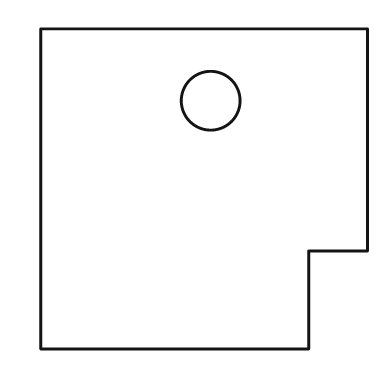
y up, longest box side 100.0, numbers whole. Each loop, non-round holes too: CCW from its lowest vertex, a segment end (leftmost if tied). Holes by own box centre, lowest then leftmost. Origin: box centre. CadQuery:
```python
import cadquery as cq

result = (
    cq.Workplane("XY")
    .moveTo(-50.0, -49.0)
    .lineTo(32.0, -49.0)
    .lineTo(32.0, -19.0)
    .lineTo(50.0, -19.0)
    .lineTo(50.0, 49.0)
    .lineTo(-50.0, 49.0)
    .close()
    .moveTo(2.0, 27.0)
    .circle(9.0)
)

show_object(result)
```